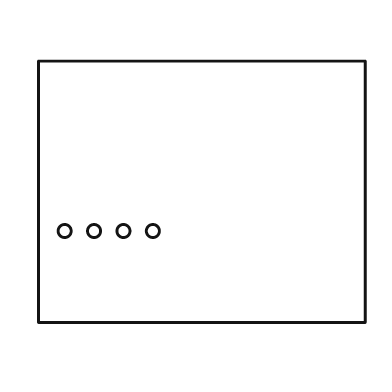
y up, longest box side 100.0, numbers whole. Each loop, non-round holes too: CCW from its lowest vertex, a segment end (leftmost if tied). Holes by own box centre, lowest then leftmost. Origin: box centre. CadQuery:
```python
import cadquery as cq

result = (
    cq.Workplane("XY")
    .moveTo(-50.0, -40.0)
    .lineTo(50.0, -40.0)
    .lineTo(50.0, 40.0)
    .lineTo(-50.0, 40.0)
    .close()
    .moveTo(-42.0, -12.0)
    .circle(2.0)
    .moveTo(-33.0, -12.0)
    .circle(2.0)
    .moveTo(-24.0, -12.0)
    .circle(2.0)
    .moveTo(-15.0, -12.0)
    .circle(2.0)
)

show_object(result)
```